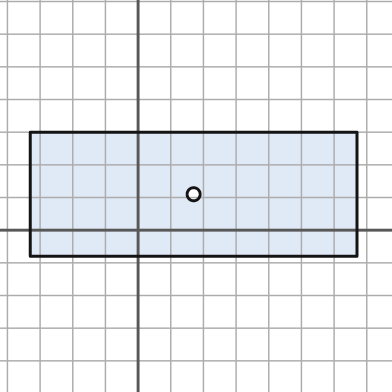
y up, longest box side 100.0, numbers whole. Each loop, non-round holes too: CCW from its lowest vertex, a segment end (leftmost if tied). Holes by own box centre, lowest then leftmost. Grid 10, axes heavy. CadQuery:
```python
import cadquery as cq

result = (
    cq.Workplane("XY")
    .moveTo(-33.0, -8.0)
    .lineTo(67.0, -8.0)
    .lineTo(67.0, 30.0)
    .lineTo(-33.0, 30.0)
    .close()
    .moveTo(17.0, 11.0)
    .circle(2.0)
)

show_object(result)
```